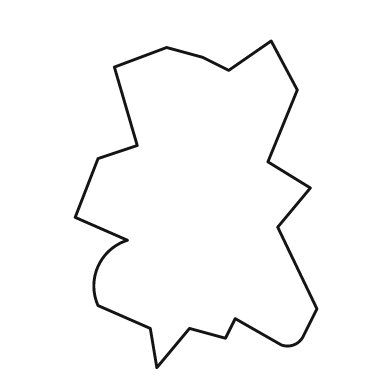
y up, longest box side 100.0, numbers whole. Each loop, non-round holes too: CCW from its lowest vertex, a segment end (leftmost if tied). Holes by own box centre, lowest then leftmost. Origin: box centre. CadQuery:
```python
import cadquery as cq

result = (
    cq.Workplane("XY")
    .moveTo(-12.0, -50.0)
    .lineTo(-2.0, -38.0)
    .lineTo(9.0, -41.0)
    .lineTo(12.0, -35.0)
    .lineTo(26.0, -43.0)
    .threePointArc((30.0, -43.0), (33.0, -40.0))
    .lineTo(37.0, -32.0)
    .lineTo(25.0, -7.0)
    .lineTo(35.0, 5.0)
    .lineTo(22.0, 13.0)
    .lineTo(31.0, 35.0)
    .lineTo(23.0, 50.0)
    .lineTo(10.0, 41.0)
    .lineTo(2.0, 45.0)
    .lineTo(-9.0, 48.0)
    .lineTo(-25.0, 42.0)
    .lineTo(-18.0, 18.0)
    .lineTo(-30.0, 14.0)
    .lineTo(-37.0, -4.0)
    .lineTo(-21.0, -11.0)
    .threePointArc((-30.0, -19.0), (-30.0, -31.0))
    .lineTo(-14.0, -38.0)
    .close()
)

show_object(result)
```